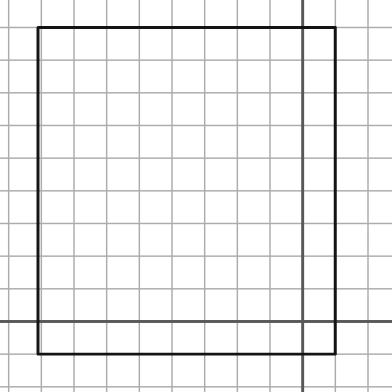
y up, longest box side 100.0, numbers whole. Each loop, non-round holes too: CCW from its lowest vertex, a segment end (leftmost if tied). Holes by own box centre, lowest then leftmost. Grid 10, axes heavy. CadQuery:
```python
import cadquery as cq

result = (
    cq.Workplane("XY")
    .moveTo(-81.0, -10.0)
    .lineTo(10.0, -10.0)
    .lineTo(10.0, 90.0)
    .lineTo(-81.0, 90.0)
    .close()
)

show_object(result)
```